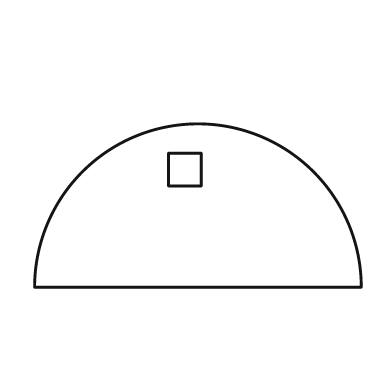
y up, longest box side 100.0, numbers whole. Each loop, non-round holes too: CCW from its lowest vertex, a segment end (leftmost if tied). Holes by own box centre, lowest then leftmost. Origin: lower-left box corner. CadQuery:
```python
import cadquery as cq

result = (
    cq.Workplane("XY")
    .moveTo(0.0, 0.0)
    .lineTo(100.0, 0.0)
    .threePointArc((50.0, 50.0), (0.0, 0.0))
    .close()
    .moveTo(41.0, 31.0)
    .lineTo(51.0, 31.0)
    .lineTo(51.0, 41.0)
    .lineTo(41.0, 41.0)
    .close()
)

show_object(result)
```